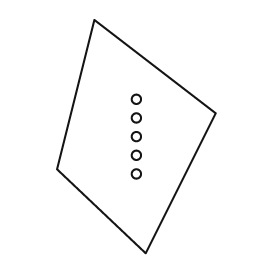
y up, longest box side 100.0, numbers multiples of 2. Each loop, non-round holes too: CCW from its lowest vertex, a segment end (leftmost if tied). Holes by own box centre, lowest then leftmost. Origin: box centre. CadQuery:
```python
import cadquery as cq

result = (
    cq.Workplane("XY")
    .moveTo(4.0, -50.0)
    .lineTo(34.0, 10.0)
    .lineTo(-18.0, 50.0)
    .lineTo(-34.0, -14.0)
    .close()
    .moveTo(0.0, -16.0)
    .circle(2.0)
    .moveTo(0.0, -8.0)
    .circle(2.0)
    .moveTo(0.0, 0.0)
    .circle(2.0)
    .moveTo(0.0, 8.0)
    .circle(2.0)
    .moveTo(0.0, 16.0)
    .circle(2.0)
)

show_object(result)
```